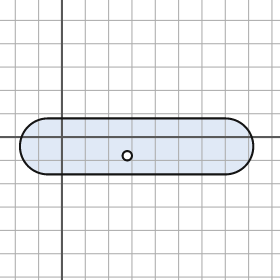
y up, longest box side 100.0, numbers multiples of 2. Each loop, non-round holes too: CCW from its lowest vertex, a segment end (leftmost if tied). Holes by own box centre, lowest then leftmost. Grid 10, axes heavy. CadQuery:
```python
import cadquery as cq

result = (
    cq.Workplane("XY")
    .moveTo(-6.0, -16.0)
    .lineTo(70.0, -16.0)
    .threePointArc((82.0, -4.0), (70.0, 8.0))
    .lineTo(-6.0, 8.0)
    .threePointArc((-18.0, -4.0), (-6.0, -16.0))
    .close()
    .moveTo(28.0, -8.0)
    .circle(2.0)
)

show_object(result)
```